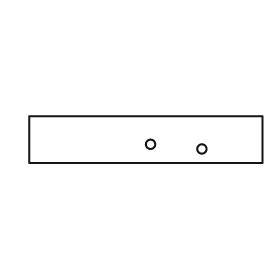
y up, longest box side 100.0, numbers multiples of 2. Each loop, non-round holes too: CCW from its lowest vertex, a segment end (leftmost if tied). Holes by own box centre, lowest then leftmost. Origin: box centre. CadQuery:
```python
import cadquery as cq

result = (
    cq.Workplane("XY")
    .moveTo(-50.0, -10.0)
    .lineTo(50.0, -10.0)
    .lineTo(50.0, 10.0)
    .lineTo(-50.0, 10.0)
    .close()
    .moveTo(24.0, -4.0)
    .circle(2.0)
    .moveTo(2.0, -2.0)
    .circle(2.0)
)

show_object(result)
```